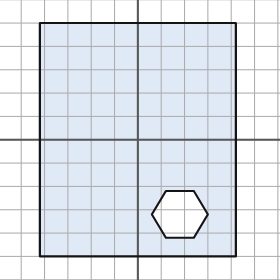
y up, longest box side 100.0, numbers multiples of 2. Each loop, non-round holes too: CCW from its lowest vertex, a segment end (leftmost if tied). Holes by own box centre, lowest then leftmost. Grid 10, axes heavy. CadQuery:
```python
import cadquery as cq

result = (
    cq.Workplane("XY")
    .moveTo(-42.0, -50.0)
    .lineTo(42.0, -50.0)
    .lineTo(42.0, 50.0)
    .lineTo(-42.0, 50.0)
    .close()
    .moveTo(12.0, -42.0)
    .lineTo(24.0, -42.0)
    .lineTo(30.0, -32.0)
    .lineTo(24.0, -22.0)
    .lineTo(12.0, -22.0)
    .lineTo(6.0, -32.0)
    .close()
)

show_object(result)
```